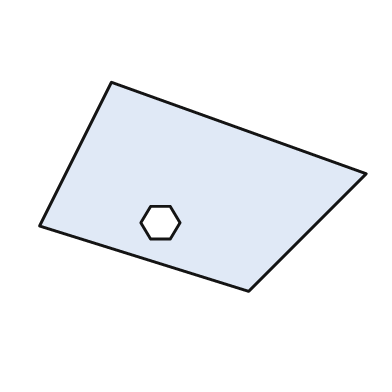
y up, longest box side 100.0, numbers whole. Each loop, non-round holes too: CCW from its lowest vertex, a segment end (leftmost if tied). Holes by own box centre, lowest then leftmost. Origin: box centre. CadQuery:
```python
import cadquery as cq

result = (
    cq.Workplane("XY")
    .moveTo(14.0, -32.0)
    .lineTo(50.0, 4.0)
    .lineTo(-28.0, 32.0)
    .lineTo(-50.0, -12.0)
    .close()
    .moveTo(-16.0, -16.0)
    .lineTo(-10.0, -16.0)
    .lineTo(-7.0, -11.0)
    .lineTo(-10.0, -6.0)
    .lineTo(-16.0, -6.0)
    .lineTo(-19.0, -11.0)
    .close()
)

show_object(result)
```